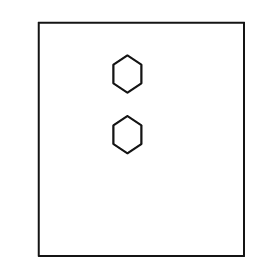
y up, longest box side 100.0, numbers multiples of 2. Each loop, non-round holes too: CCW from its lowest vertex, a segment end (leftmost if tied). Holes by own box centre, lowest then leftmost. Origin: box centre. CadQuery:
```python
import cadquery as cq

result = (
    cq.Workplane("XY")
    .moveTo(-44.0, -50.0)
    .lineTo(44.0, -50.0)
    .lineTo(44.0, 50.0)
    .lineTo(-44.0, 50.0)
    .close()
    .moveTo(-6.0, -6.0)
    .lineTo(0.0, -2.0)
    .lineTo(0.0, 6.0)
    .lineTo(-6.0, 10.0)
    .lineTo(-12.0, 6.0)
    .lineTo(-12.0, -2.0)
    .close()
    .moveTo(-6.0, 20.0)
    .lineTo(0.0, 24.0)
    .lineTo(0.0, 32.0)
    .lineTo(-6.0, 36.0)
    .lineTo(-12.0, 32.0)
    .lineTo(-12.0, 24.0)
    .close()
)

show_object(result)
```